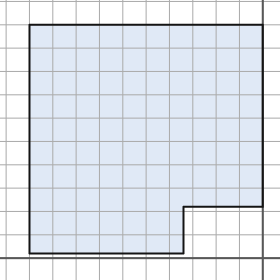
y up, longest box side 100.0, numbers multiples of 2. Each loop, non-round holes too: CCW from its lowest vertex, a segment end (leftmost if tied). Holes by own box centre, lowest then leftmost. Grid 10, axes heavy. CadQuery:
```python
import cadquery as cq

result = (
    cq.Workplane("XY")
    .moveTo(-100.0, 2.0)
    .lineTo(-34.0, 2.0)
    .lineTo(-34.0, 22.0)
    .lineTo(0.0, 22.0)
    .lineTo(0.0, 100.0)
    .lineTo(-100.0, 100.0)
    .close()
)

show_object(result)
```